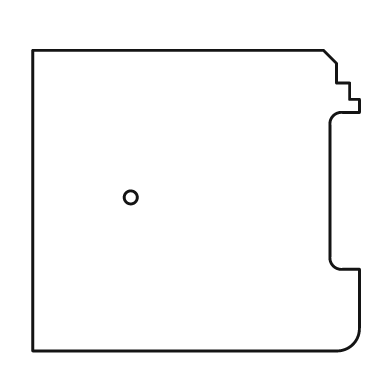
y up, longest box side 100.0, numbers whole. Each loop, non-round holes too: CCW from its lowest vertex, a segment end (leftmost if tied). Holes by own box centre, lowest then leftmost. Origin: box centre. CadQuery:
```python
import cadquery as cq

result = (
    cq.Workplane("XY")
    .moveTo(-50.0, -46.0)
    .lineTo(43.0, -46.0)
    .threePointArc((48.0, -44.0), (50.0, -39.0))
    .lineTo(50.0, -21.0)
    .lineTo(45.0, -21.0)
    .threePointArc((42.0, -20.0), (41.0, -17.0))
    .lineTo(41.0, 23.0)
    .threePointArc((42.0, 26.0), (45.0, 27.0))
    .lineTo(50.0, 27.0)
    .lineTo(50.0, 31.0)
    .lineTo(47.0, 31.0)
    .lineTo(47.0, 36.0)
    .lineTo(43.0, 36.0)
    .lineTo(43.0, 42.0)
    .lineTo(39.0, 46.0)
    .lineTo(-50.0, 46.0)
    .close()
    .moveTo(-20.0, 1.0)
    .circle(2.0)
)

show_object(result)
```